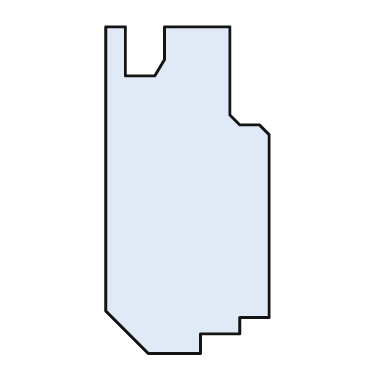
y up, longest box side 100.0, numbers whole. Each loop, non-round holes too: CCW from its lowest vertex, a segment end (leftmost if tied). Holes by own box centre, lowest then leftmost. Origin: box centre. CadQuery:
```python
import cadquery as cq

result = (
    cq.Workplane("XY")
    .moveTo(-12.0, -50.0)
    .lineTo(4.0, -50.0)
    .lineTo(4.0, -44.0)
    .lineTo(16.0, -44.0)
    .lineTo(16.0, -39.0)
    .lineTo(25.0, -39.0)
    .lineTo(25.0, 17.0)
    .lineTo(22.0, 20.0)
    .lineTo(16.0, 20.0)
    .lineTo(13.0, 23.0)
    .lineTo(13.0, 50.0)
    .lineTo(-7.0, 50.0)
    .lineTo(-7.0, 40.0)
    .lineTo(-10.0, 35.0)
    .lineTo(-19.0, 35.0)
    .lineTo(-19.0, 50.0)
    .lineTo(-25.0, 50.0)
    .lineTo(-25.0, -37.0)
    .close()
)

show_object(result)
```